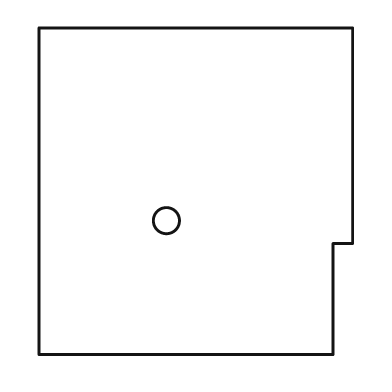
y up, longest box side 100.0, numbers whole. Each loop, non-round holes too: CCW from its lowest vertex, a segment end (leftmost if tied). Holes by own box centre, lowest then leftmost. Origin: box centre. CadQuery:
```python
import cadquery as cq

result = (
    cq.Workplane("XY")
    .moveTo(-48.0, -50.0)
    .lineTo(42.0, -50.0)
    .lineTo(42.0, -16.0)
    .lineTo(48.0, -16.0)
    .lineTo(48.0, 50.0)
    .lineTo(-48.0, 50.0)
    .close()
    .moveTo(-9.0, -9.0)
    .circle(4.0)
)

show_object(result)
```